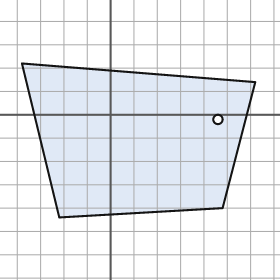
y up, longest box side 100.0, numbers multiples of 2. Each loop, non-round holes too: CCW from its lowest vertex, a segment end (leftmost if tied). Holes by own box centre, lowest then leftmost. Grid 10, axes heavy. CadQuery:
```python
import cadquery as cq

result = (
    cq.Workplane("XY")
    .moveTo(-22.0, -44.0)
    .lineTo(48.0, -40.0)
    .lineTo(62.0, 14.0)
    .lineTo(-38.0, 22.0)
    .close()
    .moveTo(46.0, -2.0)
    .circle(2.0)
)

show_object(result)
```